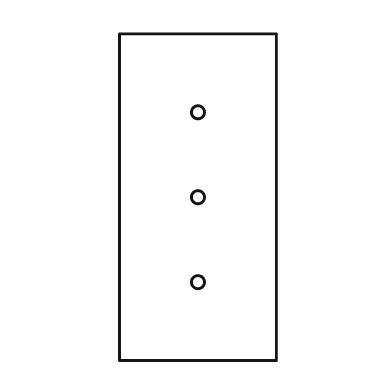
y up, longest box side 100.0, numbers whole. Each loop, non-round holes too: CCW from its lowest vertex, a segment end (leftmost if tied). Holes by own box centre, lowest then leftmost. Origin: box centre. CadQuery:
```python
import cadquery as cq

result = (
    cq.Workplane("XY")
    .moveTo(-24.0, -50.0)
    .lineTo(24.0, -50.0)
    .lineTo(24.0, 50.0)
    .lineTo(-24.0, 50.0)
    .close()
    .moveTo(0.0, -26.0)
    .circle(2.0)
    .moveTo(0.0, 0.0)
    .circle(2.0)
    .moveTo(0.0, 26.0)
    .circle(2.0)
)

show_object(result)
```